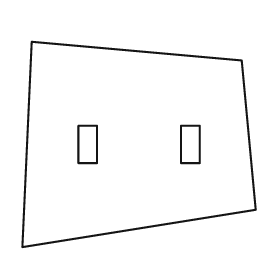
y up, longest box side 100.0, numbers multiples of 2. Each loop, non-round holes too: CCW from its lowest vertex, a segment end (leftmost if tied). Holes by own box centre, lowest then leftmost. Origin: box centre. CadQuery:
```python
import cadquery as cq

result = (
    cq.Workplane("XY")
    .moveTo(-50.0, -44.0)
    .lineTo(50.0, -28.0)
    .lineTo(44.0, 36.0)
    .lineTo(-46.0, 44.0)
    .close()
    .moveTo(-26.0, -8.0)
    .lineTo(-18.0, -8.0)
    .lineTo(-18.0, 8.0)
    .lineTo(-26.0, 8.0)
    .close()
    .moveTo(18.0, -8.0)
    .lineTo(26.0, -8.0)
    .lineTo(26.0, 8.0)
    .lineTo(18.0, 8.0)
    .close()
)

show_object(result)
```